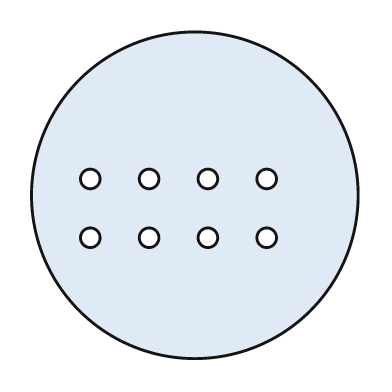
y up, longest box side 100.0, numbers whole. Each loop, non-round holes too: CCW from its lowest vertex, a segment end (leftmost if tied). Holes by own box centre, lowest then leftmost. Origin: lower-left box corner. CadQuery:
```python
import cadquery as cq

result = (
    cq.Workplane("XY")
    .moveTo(50.0, 50.0)
    .circle(50.0)
    .moveTo(18.0, 37.0)
    .circle(3.0)
    .moveTo(36.0, 37.0)
    .circle(3.0)
    .moveTo(54.0, 37.0)
    .circle(3.0)
    .moveTo(72.0, 37.0)
    .circle(3.0)
    .moveTo(18.0, 55.0)
    .circle(3.0)
    .moveTo(36.0, 55.0)
    .circle(3.0)
    .moveTo(54.0, 55.0)
    .circle(3.0)
    .moveTo(72.0, 55.0)
    .circle(3.0)
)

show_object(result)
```